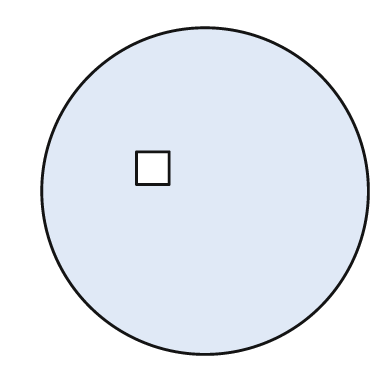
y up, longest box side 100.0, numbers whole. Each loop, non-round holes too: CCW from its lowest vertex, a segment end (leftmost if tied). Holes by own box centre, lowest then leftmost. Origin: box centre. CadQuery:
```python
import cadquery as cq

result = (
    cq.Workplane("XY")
    .moveTo(0.0, 0.0)
    .circle(50.0)
    .moveTo(-21.0, 2.0)
    .lineTo(-11.0, 2.0)
    .lineTo(-11.0, 12.0)
    .lineTo(-21.0, 12.0)
    .close()
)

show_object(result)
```